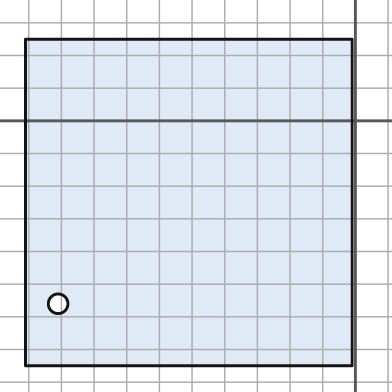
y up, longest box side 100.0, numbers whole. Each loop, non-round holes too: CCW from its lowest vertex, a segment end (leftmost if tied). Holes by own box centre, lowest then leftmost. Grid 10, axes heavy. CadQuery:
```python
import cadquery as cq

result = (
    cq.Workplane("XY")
    .moveTo(-101.0, -75.0)
    .lineTo(-1.0, -75.0)
    .lineTo(-1.0, 25.0)
    .lineTo(-101.0, 25.0)
    .close()
    .moveTo(-91.0, -56.0)
    .circle(3.0)
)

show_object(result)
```